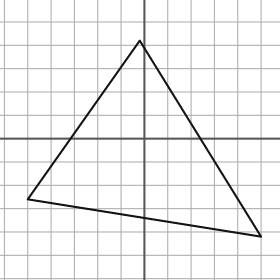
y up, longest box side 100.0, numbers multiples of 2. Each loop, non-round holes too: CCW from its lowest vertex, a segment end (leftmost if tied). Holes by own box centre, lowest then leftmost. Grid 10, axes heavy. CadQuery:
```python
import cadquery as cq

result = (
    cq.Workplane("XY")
    .moveTo(50.0, -42.0)
    .lineTo(-2.0, 42.0)
    .lineTo(-50.0, -26.0)
    .close()
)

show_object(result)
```